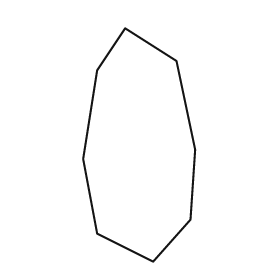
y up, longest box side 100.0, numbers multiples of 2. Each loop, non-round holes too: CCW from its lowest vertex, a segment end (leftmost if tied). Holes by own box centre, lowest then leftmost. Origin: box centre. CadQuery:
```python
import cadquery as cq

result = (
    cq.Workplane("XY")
    .moveTo(6.0, -50.0)
    .lineTo(22.0, -32.0)
    .lineTo(24.0, -2.0)
    .lineTo(16.0, 36.0)
    .lineTo(-6.0, 50.0)
    .lineTo(-18.0, 32.0)
    .lineTo(-24.0, -6.0)
    .lineTo(-18.0, -38.0)
    .close()
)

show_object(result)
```